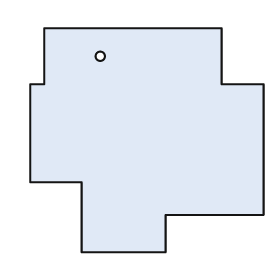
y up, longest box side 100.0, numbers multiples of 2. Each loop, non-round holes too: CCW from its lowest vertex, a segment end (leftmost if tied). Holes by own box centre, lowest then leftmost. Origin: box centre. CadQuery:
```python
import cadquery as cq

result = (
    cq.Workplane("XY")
    .moveTo(-28.0, -48.0)
    .lineTo(8.0, -48.0)
    .lineTo(8.0, -32.0)
    .lineTo(50.0, -32.0)
    .lineTo(50.0, 24.0)
    .lineTo(32.0, 24.0)
    .lineTo(32.0, 48.0)
    .lineTo(-44.0, 48.0)
    .lineTo(-44.0, 24.0)
    .lineTo(-50.0, 24.0)
    .lineTo(-50.0, -18.0)
    .lineTo(-28.0, -18.0)
    .close()
    .moveTo(-20.0, 36.0)
    .circle(2.0)
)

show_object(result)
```